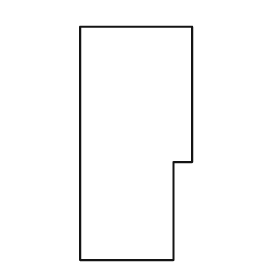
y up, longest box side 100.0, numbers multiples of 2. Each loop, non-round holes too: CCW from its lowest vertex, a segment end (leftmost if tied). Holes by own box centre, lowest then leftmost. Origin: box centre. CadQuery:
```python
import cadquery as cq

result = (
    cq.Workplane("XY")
    .moveTo(-24.0, -50.0)
    .lineTo(16.0, -50.0)
    .lineTo(16.0, -8.0)
    .lineTo(24.0, -8.0)
    .lineTo(24.0, 50.0)
    .lineTo(-24.0, 50.0)
    .close()
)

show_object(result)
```